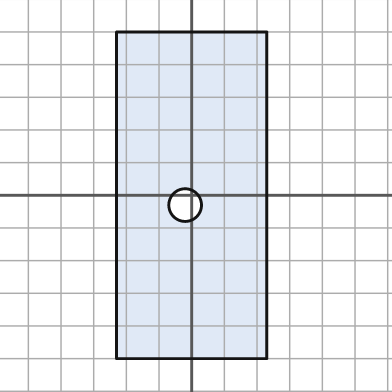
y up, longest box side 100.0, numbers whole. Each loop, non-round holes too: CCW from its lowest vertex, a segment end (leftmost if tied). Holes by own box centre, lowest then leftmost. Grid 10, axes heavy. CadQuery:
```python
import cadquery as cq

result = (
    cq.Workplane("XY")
    .moveTo(-23.0, -50.0)
    .lineTo(23.0, -50.0)
    .lineTo(23.0, 50.0)
    .lineTo(-23.0, 50.0)
    .close()
    .moveTo(-2.0, -3.0)
    .circle(5.0)
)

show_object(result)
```